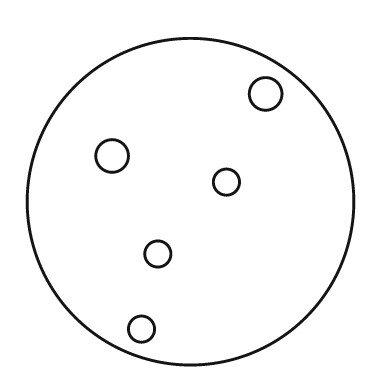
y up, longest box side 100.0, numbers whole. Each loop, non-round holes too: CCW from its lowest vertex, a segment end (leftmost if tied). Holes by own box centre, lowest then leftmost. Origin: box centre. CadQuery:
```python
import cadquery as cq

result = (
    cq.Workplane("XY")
    .moveTo(0.0, 0.0)
    .circle(50.0)
    .moveTo(-15.0, -39.0)
    .circle(4.0)
    .moveTo(-10.0, -16.0)
    .circle(4.0)
    .moveTo(11.0, 6.0)
    .circle(4.0)
    .moveTo(-24.0, 14.0)
    .circle(5.0)
    .moveTo(23.0, 33.0)
    .circle(5.0)
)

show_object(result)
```